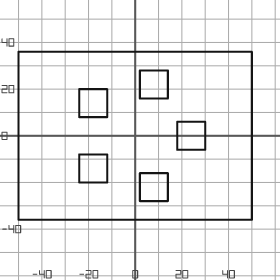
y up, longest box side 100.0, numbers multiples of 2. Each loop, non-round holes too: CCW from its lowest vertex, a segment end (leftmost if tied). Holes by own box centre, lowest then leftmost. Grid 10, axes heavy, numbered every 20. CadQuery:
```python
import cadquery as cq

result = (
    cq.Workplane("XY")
    .moveTo(-50.0, -36.0)
    .lineTo(50.0, -36.0)
    .lineTo(50.0, 36.0)
    .lineTo(-50.0, 36.0)
    .close()
    .moveTo(2.0, -28.0)
    .lineTo(14.0, -28.0)
    .lineTo(14.0, -16.0)
    .lineTo(2.0, -16.0)
    .close()
    .moveTo(-24.0, -20.0)
    .lineTo(-12.0, -20.0)
    .lineTo(-12.0, -8.0)
    .lineTo(-24.0, -8.0)
    .close()
    .moveTo(18.0, -6.0)
    .lineTo(30.0, -6.0)
    .lineTo(30.0, 6.0)
    .lineTo(18.0, 6.0)
    .close()
    .moveTo(-24.0, 8.0)
    .lineTo(-12.0, 8.0)
    .lineTo(-12.0, 20.0)
    .lineTo(-24.0, 20.0)
    .close()
    .moveTo(2.0, 16.0)
    .lineTo(14.0, 16.0)
    .lineTo(14.0, 28.0)
    .lineTo(2.0, 28.0)
    .close()
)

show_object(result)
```